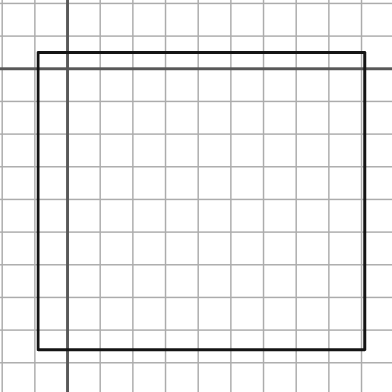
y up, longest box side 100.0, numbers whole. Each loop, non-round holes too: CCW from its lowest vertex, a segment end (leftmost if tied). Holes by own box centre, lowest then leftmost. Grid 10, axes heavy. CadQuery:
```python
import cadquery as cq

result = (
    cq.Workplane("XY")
    .moveTo(-9.0, -86.0)
    .lineTo(91.0, -86.0)
    .lineTo(91.0, 5.0)
    .lineTo(-9.0, 5.0)
    .close()
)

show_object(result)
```